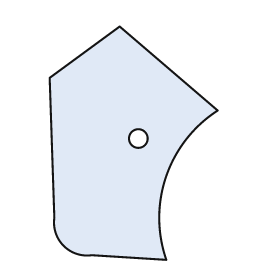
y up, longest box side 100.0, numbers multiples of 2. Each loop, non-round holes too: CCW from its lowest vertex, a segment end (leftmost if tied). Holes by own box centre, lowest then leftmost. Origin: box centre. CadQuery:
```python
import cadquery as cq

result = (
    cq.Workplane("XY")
    .moveTo(14.0, -50.0)
    .threePointArc((14.0, -14.0), (36.0, 14.0))
    .lineTo(-6.0, 50.0)
    .lineTo(-36.0, 28.0)
    .lineTo(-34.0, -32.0)
    .threePointArc((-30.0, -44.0), (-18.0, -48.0))
    .close()
    .moveTo(2.0, 2.0)
    .circle(4.0)
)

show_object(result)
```